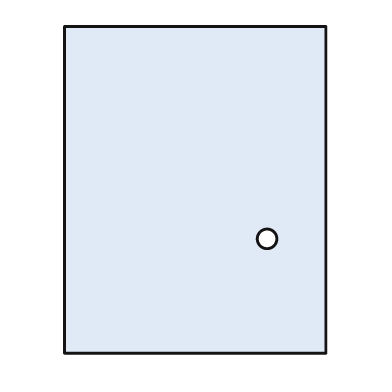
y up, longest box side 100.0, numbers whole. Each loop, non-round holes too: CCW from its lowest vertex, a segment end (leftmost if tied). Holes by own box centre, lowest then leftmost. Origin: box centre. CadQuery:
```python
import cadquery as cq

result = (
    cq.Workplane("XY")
    .moveTo(-40.0, -50.0)
    .lineTo(40.0, -50.0)
    .lineTo(40.0, 50.0)
    .lineTo(-40.0, 50.0)
    .close()
    .moveTo(22.0, -15.0)
    .circle(3.0)
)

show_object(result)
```